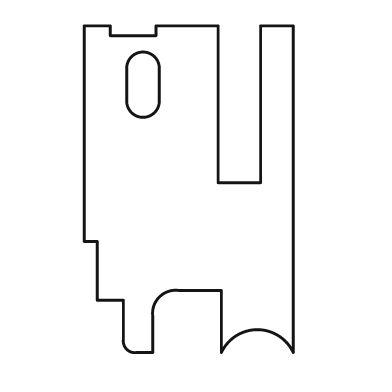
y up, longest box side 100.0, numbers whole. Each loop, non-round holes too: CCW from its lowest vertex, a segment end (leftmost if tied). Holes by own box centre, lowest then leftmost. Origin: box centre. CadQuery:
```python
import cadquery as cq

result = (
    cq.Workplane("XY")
    .moveTo(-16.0, -50.0)
    .lineTo(-11.0, -50.0)
    .lineTo(-11.0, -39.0)
    .threePointArc((-9.0, -33.0), (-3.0, -31.0))
    .lineTo(10.0, -31.0)
    .lineTo(10.0, -50.0)
    .threePointArc((21.0, -43.0), (32.0, -50.0))
    .lineTo(32.0, 50.0)
    .lineTo(22.0, 50.0)
    .lineTo(22.0, 2.0)
    .lineTo(9.0, 2.0)
    .lineTo(9.0, 50.0)
    .lineTo(-10.0, 50.0)
    .lineTo(-10.0, 47.0)
    .lineTo(-24.0, 47.0)
    .lineTo(-24.0, 50.0)
    .lineTo(-32.0, 50.0)
    .lineTo(-32.0, -16.0)
    .lineTo(-28.0, -16.0)
    .lineTo(-28.0, -34.0)
    .lineTo(-20.0, -34.0)
    .lineTo(-20.0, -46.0)
    .threePointArc((-19.0, -49.0), (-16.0, -50.0))
    .close()
    .moveTo(-19.0, 27.0)
    .threePointArc((-14.0, 22.0), (-9.0, 27.0))
    .lineTo(-9.0, 37.0)
    .threePointArc((-14.0, 42.0), (-19.0, 37.0))
    .close()
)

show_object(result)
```